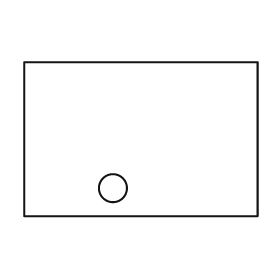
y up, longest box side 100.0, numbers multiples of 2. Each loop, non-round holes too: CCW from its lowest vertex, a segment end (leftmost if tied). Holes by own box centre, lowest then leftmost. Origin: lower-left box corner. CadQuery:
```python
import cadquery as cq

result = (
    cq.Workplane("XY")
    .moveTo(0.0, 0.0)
    .lineTo(100.0, 0.0)
    .lineTo(100.0, 66.0)
    .lineTo(0.0, 66.0)
    .close()
    .moveTo(38.0, 12.0)
    .circle(6.0)
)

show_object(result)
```